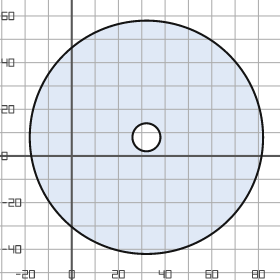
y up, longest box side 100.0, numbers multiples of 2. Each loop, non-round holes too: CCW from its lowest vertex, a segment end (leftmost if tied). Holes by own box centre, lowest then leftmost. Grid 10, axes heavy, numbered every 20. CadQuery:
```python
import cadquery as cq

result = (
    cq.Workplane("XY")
    .moveTo(32.0, 8.0)
    .circle(50.0)
    .moveTo(32.0, 8.0)
    .circle(6.0)
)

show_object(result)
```